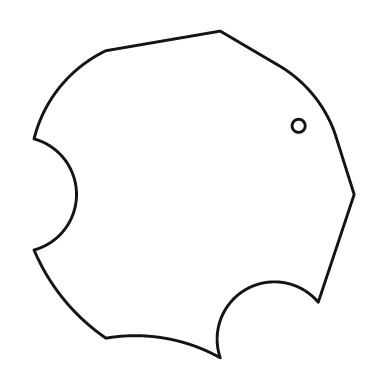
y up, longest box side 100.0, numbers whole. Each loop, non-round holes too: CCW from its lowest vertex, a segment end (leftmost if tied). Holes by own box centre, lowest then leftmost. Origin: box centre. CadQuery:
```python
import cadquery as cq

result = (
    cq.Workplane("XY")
    .moveTo(8.0, -50.0)
    .threePointArc((16.0, -29.0), (38.0, -33.0))
    .lineTo(49.0, 0.0)
    .lineTo(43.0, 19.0)
    .threePointArc((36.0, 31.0), (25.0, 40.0))
    .lineTo(8.0, 50.0)
    .lineTo(-27.0, 44.0)
    .threePointArc((-41.0, 33.0), (-49.0, 17.0))
    .threePointArc((-36.0, 0.0), (-49.0, -17.0))
    .threePointArc((-40.0, -32.0), (-27.0, -44.0))
    .threePointArc((-9.0, -44.0), (8.0, -50.0))
    .close()
    .moveTo(32.0, 21.0)
    .circle(2.0)
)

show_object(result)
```